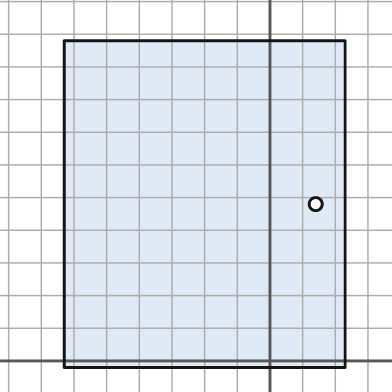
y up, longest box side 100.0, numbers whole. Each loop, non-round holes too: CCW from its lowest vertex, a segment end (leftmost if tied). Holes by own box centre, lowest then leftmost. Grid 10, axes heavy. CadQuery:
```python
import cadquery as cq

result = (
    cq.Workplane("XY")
    .moveTo(-63.0, -2.0)
    .lineTo(23.0, -2.0)
    .lineTo(23.0, 98.0)
    .lineTo(-63.0, 98.0)
    .close()
    .moveTo(14.0, 48.0)
    .circle(2.0)
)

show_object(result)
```